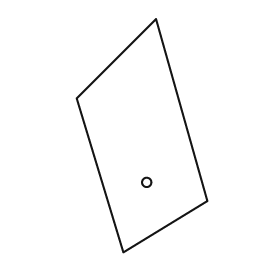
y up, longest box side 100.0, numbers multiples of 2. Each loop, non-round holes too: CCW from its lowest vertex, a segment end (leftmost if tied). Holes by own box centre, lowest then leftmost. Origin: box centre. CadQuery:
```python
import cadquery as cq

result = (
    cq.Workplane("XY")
    .moveTo(-8.0, -50.0)
    .lineTo(28.0, -28.0)
    .lineTo(6.0, 50.0)
    .lineTo(-28.0, 16.0)
    .close()
    .moveTo(2.0, -20.0)
    .circle(2.0)
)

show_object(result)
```